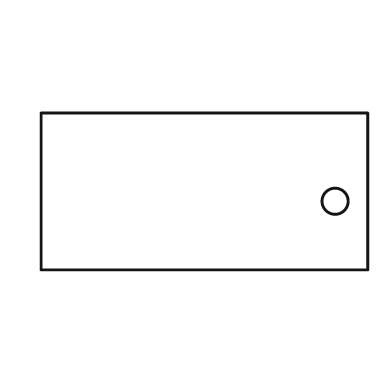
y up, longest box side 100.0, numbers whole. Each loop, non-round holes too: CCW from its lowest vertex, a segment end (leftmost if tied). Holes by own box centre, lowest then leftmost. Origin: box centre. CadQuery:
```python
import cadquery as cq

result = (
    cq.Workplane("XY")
    .moveTo(-50.0, -24.0)
    .lineTo(50.0, -24.0)
    .lineTo(50.0, 24.0)
    .lineTo(-50.0, 24.0)
    .close()
    .moveTo(40.0, -3.0)
    .circle(4.0)
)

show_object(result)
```